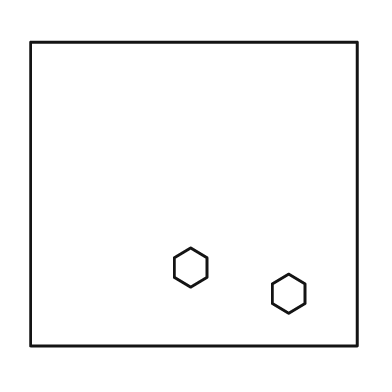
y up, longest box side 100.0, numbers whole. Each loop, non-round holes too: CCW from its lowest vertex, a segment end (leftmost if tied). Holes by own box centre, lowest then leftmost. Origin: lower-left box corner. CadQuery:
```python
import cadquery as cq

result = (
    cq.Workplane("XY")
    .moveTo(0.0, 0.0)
    .lineTo(100.0, 0.0)
    .lineTo(100.0, 93.0)
    .lineTo(0.0, 93.0)
    .close()
    .moveTo(79.0, 10.0)
    .lineTo(84.0, 13.0)
    .lineTo(84.0, 19.0)
    .lineTo(79.0, 22.0)
    .lineTo(74.0, 19.0)
    .lineTo(74.0, 13.0)
    .close()
    .moveTo(49.0, 18.0)
    .lineTo(54.0, 21.0)
    .lineTo(54.0, 27.0)
    .lineTo(49.0, 30.0)
    .lineTo(44.0, 27.0)
    .lineTo(44.0, 21.0)
    .close()
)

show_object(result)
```